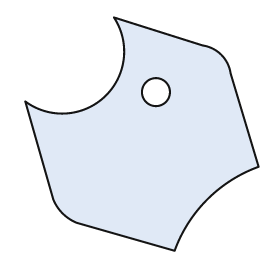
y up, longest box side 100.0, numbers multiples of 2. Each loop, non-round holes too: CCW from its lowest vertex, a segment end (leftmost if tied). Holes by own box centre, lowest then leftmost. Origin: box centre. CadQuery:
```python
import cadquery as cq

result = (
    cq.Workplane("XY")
    .moveTo(14.0, -50.0)
    .threePointArc((28.0, -28.0), (50.0, -14.0))
    .lineTo(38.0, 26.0)
    .threePointArc((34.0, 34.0), (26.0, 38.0))
    .lineTo(-12.0, 50.0)
    .threePointArc((-16.0, 16.0), (-50.0, 14.0))
    .lineTo(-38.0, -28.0)
    .threePointArc((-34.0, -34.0), (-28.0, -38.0))
    .close()
    .moveTo(6.0, 18.0)
    .circle(6.0)
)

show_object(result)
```